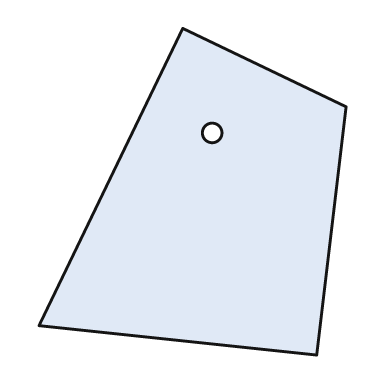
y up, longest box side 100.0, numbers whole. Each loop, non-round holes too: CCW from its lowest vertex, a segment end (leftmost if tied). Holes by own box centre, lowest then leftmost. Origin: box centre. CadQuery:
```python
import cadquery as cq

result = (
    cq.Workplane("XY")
    .moveTo(38.0, -50.0)
    .lineTo(47.0, 26.0)
    .lineTo(-3.0, 50.0)
    .lineTo(-47.0, -41.0)
    .close()
    .moveTo(6.0, 18.0)
    .circle(3.0)
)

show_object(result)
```